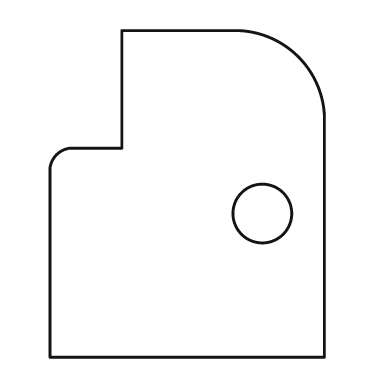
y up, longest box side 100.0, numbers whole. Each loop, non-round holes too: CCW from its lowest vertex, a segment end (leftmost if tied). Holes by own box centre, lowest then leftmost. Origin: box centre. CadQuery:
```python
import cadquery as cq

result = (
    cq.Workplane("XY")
    .moveTo(-42.0, -50.0)
    .lineTo(42.0, -50.0)
    .lineTo(42.0, 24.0)
    .threePointArc((34.0, 42.0), (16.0, 50.0))
    .lineTo(-20.0, 50.0)
    .lineTo(-20.0, 14.0)
    .lineTo(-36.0, 14.0)
    .threePointArc((-40.0, 12.0), (-42.0, 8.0))
    .close()
    .moveTo(23.0, -6.0)
    .circle(9.0)
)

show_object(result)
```